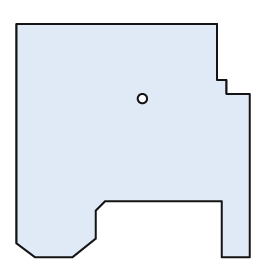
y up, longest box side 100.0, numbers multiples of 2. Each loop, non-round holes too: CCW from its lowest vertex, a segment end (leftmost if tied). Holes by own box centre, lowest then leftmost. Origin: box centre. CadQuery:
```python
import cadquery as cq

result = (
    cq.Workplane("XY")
    .moveTo(-42.0, -50.0)
    .lineTo(-26.0, -50.0)
    .lineTo(-16.0, -42.0)
    .lineTo(-16.0, -30.0)
    .lineTo(-12.0, -26.0)
    .lineTo(38.0, -26.0)
    .lineTo(38.0, -50.0)
    .lineTo(50.0, -50.0)
    .lineTo(50.0, 20.0)
    .lineTo(40.0, 20.0)
    .lineTo(40.0, 26.0)
    .lineTo(36.0, 26.0)
    .lineTo(36.0, 50.0)
    .lineTo(-50.0, 50.0)
    .lineTo(-50.0, -44.0)
    .close()
    .moveTo(4.0, 18.0)
    .circle(2.0)
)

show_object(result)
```